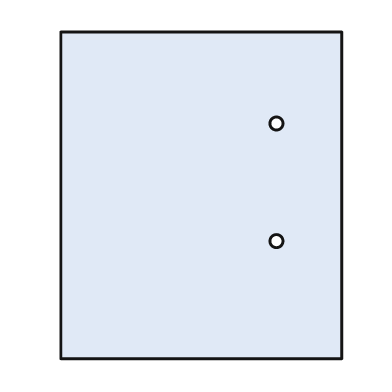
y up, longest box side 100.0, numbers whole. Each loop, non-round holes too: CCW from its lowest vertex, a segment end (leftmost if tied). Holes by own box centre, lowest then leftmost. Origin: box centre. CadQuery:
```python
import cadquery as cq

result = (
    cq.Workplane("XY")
    .moveTo(-43.0, -50.0)
    .lineTo(43.0, -50.0)
    .lineTo(43.0, 50.0)
    .lineTo(-43.0, 50.0)
    .close()
    .moveTo(23.0, -14.0)
    .circle(2.0)
    .moveTo(23.0, 22.0)
    .circle(2.0)
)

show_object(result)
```